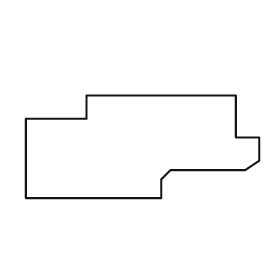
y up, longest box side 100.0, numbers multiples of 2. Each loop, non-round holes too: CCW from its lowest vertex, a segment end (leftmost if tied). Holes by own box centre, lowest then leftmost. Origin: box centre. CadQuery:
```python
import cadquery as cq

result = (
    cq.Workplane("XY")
    .moveTo(-50.0, -22.0)
    .lineTo(8.0, -22.0)
    .lineTo(8.0, -14.0)
    .lineTo(12.0, -10.0)
    .lineTo(44.0, -10.0)
    .lineTo(50.0, -6.0)
    .lineTo(50.0, 4.0)
    .lineTo(40.0, 4.0)
    .lineTo(40.0, 22.0)
    .lineTo(-24.0, 22.0)
    .lineTo(-24.0, 12.0)
    .lineTo(-50.0, 12.0)
    .close()
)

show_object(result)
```